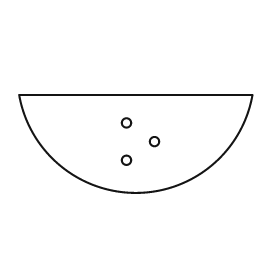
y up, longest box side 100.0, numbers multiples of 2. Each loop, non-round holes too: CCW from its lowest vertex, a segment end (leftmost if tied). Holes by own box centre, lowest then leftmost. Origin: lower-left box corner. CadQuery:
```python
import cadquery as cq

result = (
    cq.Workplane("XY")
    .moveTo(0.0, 42.0)
    .threePointArc((50.0, 0.0), (100.0, 42.0))
    .close()
    .moveTo(46.0, 14.0)
    .circle(2.0)
    .moveTo(58.0, 22.0)
    .circle(2.0)
    .moveTo(46.0, 30.0)
    .circle(2.0)
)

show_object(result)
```